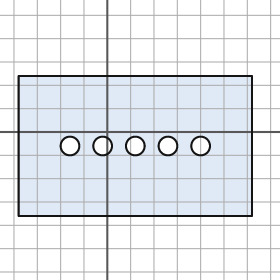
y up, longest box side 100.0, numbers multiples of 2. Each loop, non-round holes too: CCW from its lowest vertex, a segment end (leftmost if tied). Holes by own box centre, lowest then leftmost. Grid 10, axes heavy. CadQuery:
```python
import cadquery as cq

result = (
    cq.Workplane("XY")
    .moveTo(-38.0, -36.0)
    .lineTo(62.0, -36.0)
    .lineTo(62.0, 24.0)
    .lineTo(-38.0, 24.0)
    .close()
    .moveTo(-16.0, -6.0)
    .circle(4.0)
    .moveTo(-2.0, -6.0)
    .circle(4.0)
    .moveTo(12.0, -6.0)
    .circle(4.0)
    .moveTo(26.0, -6.0)
    .circle(4.0)
    .moveTo(40.0, -6.0)
    .circle(4.0)
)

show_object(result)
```